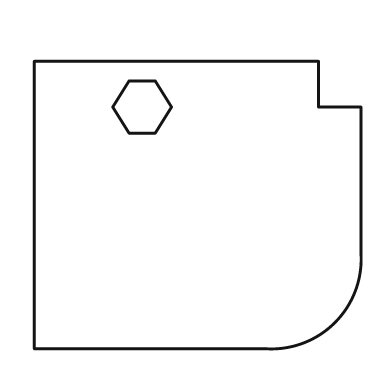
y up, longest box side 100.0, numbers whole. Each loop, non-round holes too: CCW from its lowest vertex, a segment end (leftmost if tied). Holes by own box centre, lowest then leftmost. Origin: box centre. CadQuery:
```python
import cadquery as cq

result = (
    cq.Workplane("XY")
    .moveTo(-50.0, -44.0)
    .lineTo(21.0, -44.0)
    .threePointArc((42.0, -36.0), (50.0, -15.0))
    .lineTo(50.0, 30.0)
    .lineTo(37.0, 30.0)
    .lineTo(37.0, 44.0)
    .lineTo(-50.0, 44.0)
    .close()
    .moveTo(-21.0, 22.0)
    .lineTo(-13.0, 22.0)
    .lineTo(-8.0, 30.0)
    .lineTo(-13.0, 38.0)
    .lineTo(-21.0, 38.0)
    .lineTo(-26.0, 30.0)
    .close()
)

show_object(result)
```